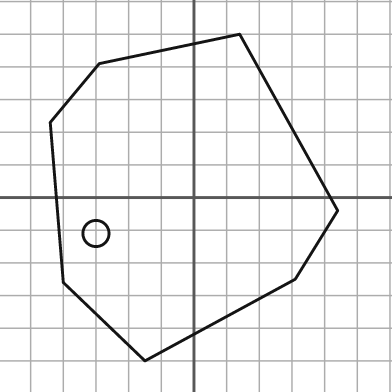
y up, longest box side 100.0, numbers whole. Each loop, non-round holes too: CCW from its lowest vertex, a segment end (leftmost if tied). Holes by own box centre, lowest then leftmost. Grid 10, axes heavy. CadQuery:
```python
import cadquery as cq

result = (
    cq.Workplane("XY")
    .moveTo(-15.0, -50.0)
    .lineTo(31.0, -25.0)
    .lineTo(44.0, -4.0)
    .lineTo(14.0, 50.0)
    .lineTo(-29.0, 41.0)
    .lineTo(-44.0, 23.0)
    .lineTo(-40.0, -26.0)
    .close()
    .moveTo(-30.0, -11.0)
    .circle(4.0)
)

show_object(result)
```